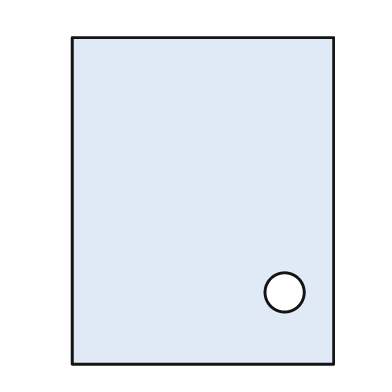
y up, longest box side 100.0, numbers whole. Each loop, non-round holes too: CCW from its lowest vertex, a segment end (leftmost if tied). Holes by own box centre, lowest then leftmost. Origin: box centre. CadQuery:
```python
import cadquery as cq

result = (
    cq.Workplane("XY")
    .moveTo(-40.0, -50.0)
    .lineTo(40.0, -50.0)
    .lineTo(40.0, 50.0)
    .lineTo(-40.0, 50.0)
    .close()
    .moveTo(25.0, -28.0)
    .circle(6.0)
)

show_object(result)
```